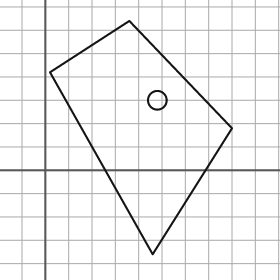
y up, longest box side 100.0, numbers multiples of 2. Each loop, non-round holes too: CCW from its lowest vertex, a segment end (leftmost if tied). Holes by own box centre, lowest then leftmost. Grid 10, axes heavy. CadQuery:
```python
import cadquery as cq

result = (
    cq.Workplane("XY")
    .moveTo(46.0, -36.0)
    .lineTo(80.0, 18.0)
    .lineTo(36.0, 64.0)
    .lineTo(2.0, 42.0)
    .close()
    .moveTo(48.0, 30.0)
    .circle(4.0)
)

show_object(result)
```